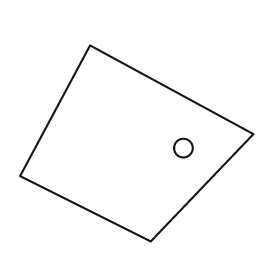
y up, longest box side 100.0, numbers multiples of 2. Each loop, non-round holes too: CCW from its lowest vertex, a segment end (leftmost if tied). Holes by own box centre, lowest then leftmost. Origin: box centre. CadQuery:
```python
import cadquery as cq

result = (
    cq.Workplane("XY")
    .moveTo(6.0, -42.0)
    .lineTo(50.0, 4.0)
    .lineTo(-20.0, 42.0)
    .lineTo(-50.0, -14.0)
    .close()
    .moveTo(20.0, -2.0)
    .circle(4.0)
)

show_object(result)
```